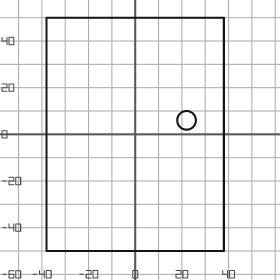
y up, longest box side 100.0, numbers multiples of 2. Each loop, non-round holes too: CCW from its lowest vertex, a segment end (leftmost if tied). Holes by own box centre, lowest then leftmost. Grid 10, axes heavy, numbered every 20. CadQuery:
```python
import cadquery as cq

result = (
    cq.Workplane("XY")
    .moveTo(-38.0, -50.0)
    .lineTo(38.0, -50.0)
    .lineTo(38.0, 50.0)
    .lineTo(-38.0, 50.0)
    .close()
    .moveTo(22.0, 6.0)
    .circle(4.0)
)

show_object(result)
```